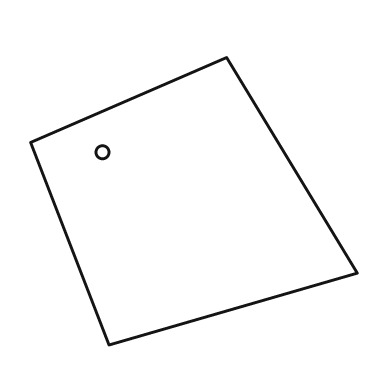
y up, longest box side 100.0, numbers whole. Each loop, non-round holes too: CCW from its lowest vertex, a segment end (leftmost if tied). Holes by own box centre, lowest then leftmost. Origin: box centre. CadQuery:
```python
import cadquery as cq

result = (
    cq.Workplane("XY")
    .moveTo(-26.0, -44.0)
    .lineTo(50.0, -22.0)
    .lineTo(10.0, 44.0)
    .lineTo(-50.0, 18.0)
    .close()
    .moveTo(-28.0, 15.0)
    .circle(2.0)
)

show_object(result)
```